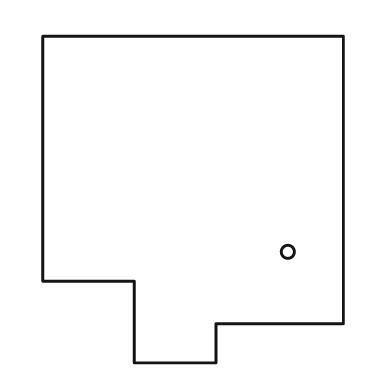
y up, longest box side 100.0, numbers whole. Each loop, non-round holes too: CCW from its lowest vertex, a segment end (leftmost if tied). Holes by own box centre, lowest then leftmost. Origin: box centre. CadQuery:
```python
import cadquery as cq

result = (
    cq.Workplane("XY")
    .moveTo(-18.0, -50.0)
    .lineTo(7.0, -50.0)
    .lineTo(7.0, -38.0)
    .lineTo(46.0, -38.0)
    .lineTo(46.0, 50.0)
    .lineTo(-46.0, 50.0)
    .lineTo(-46.0, -25.0)
    .lineTo(-18.0, -25.0)
    .close()
    .moveTo(29.0, -16.0)
    .circle(2.0)
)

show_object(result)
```